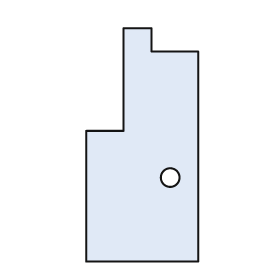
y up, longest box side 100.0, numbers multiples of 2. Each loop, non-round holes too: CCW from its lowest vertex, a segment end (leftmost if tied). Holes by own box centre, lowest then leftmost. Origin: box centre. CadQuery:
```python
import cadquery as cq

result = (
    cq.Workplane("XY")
    .moveTo(-24.0, -50.0)
    .lineTo(24.0, -50.0)
    .lineTo(24.0, 40.0)
    .lineTo(4.0, 40.0)
    .lineTo(4.0, 50.0)
    .lineTo(-8.0, 50.0)
    .lineTo(-8.0, 6.0)
    .lineTo(-24.0, 6.0)
    .close()
    .moveTo(12.0, -14.0)
    .circle(4.0)
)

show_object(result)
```